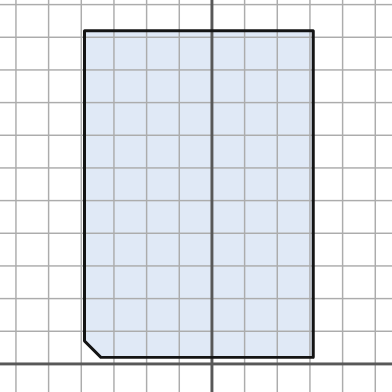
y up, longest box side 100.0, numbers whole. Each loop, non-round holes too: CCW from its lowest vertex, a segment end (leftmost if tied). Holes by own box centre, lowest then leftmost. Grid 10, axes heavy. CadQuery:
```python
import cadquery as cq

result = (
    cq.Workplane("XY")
    .moveTo(-34.0, 2.0)
    .lineTo(31.0, 2.0)
    .lineTo(31.0, 102.0)
    .lineTo(-39.0, 102.0)
    .lineTo(-39.0, 7.0)
    .close()
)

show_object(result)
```